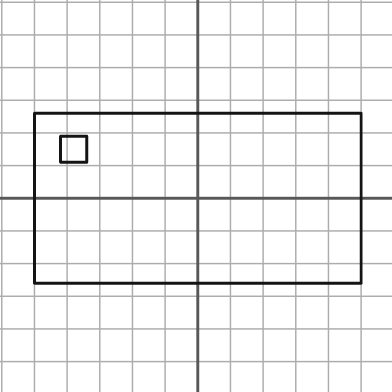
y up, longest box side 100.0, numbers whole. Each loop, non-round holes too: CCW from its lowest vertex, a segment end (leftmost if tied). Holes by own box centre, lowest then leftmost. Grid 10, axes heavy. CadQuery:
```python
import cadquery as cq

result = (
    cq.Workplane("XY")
    .moveTo(-50.0, -26.0)
    .lineTo(50.0, -26.0)
    .lineTo(50.0, 26.0)
    .lineTo(-50.0, 26.0)
    .close()
    .moveTo(-42.0, 11.0)
    .lineTo(-34.0, 11.0)
    .lineTo(-34.0, 19.0)
    .lineTo(-42.0, 19.0)
    .close()
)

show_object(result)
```